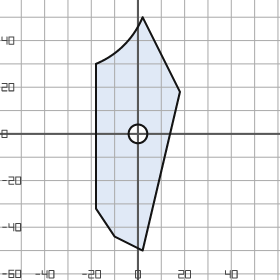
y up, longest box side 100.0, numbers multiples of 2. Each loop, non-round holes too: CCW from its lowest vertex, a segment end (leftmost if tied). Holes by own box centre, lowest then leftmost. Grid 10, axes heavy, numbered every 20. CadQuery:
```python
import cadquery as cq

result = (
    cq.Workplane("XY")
    .moveTo(2.0, -50.0)
    .lineTo(18.0, 18.0)
    .lineTo(2.0, 50.0)
    .threePointArc((-6.0, 38.0), (-18.0, 30.0))
    .lineTo(-18.0, -32.0)
    .lineTo(-10.0, -44.0)
    .close()
    .moveTo(0.0, 0.0)
    .circle(4.0)
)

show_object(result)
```